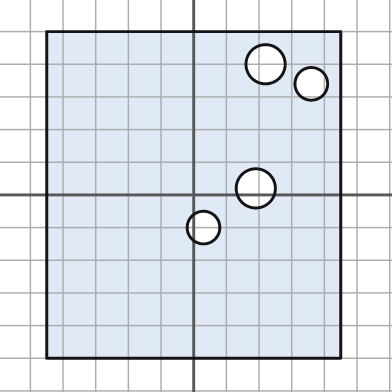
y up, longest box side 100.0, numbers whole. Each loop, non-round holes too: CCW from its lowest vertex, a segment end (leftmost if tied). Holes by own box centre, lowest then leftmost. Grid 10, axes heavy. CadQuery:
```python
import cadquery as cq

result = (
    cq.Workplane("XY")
    .moveTo(-45.0, -50.0)
    .lineTo(45.0, -50.0)
    .lineTo(45.0, 50.0)
    .lineTo(-45.0, 50.0)
    .close()
    .moveTo(3.0, -10.0)
    .circle(5.0)
    .moveTo(19.0, 2.0)
    .circle(6.0)
    .moveTo(36.0, 34.0)
    .circle(5.0)
    .moveTo(22.0, 40.0)
    .circle(6.0)
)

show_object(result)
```